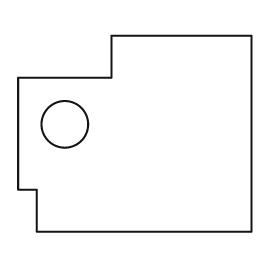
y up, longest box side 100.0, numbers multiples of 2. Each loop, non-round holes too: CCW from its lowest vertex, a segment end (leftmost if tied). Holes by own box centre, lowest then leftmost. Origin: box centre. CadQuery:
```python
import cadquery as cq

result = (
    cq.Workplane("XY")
    .moveTo(-42.0, -42.0)
    .lineTo(50.0, -42.0)
    .lineTo(50.0, 42.0)
    .lineTo(-10.0, 42.0)
    .lineTo(-10.0, 24.0)
    .lineTo(-50.0, 24.0)
    .lineTo(-50.0, -24.0)
    .lineTo(-42.0, -24.0)
    .close()
    .moveTo(-30.0, 4.0)
    .circle(10.0)
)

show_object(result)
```